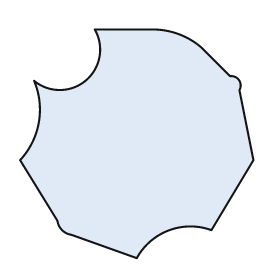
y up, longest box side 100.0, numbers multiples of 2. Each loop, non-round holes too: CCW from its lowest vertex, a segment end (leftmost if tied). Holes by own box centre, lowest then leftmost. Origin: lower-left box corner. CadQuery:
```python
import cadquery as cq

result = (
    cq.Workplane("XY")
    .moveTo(50.0, 0.0)
    .threePointArc((64.0, 12.0), (82.0, 12.0))
    .lineTo(100.0, 42.0)
    .lineTo(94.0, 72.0)
    .threePointArc((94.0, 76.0), (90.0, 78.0))
    .lineTo(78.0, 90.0)
    .threePointArc((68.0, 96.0), (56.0, 98.0))
    .lineTo(32.0, 98.0)
    .threePointArc((28.0, 76.0), (6.0, 76.0))
    .threePointArc((8.0, 58.0), (0.0, 42.0))
    .lineTo(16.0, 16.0)
    .threePointArc((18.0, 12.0), (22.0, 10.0))
    .close()
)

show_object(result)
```